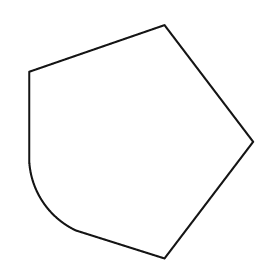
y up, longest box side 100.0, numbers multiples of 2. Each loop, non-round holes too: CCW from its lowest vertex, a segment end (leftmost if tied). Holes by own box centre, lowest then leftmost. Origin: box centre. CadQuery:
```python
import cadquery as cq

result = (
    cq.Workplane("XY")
    .moveTo(10.0, -50.0)
    .lineTo(48.0, 0.0)
    .lineTo(10.0, 50.0)
    .lineTo(-48.0, 30.0)
    .lineTo(-48.0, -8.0)
    .threePointArc((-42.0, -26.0), (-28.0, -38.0))
    .close()
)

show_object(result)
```